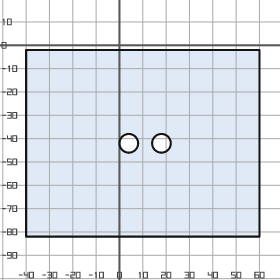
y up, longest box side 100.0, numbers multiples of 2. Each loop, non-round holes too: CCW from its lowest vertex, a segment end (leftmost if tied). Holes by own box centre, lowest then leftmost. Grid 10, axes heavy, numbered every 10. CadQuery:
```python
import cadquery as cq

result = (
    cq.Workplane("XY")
    .moveTo(-40.0, -82.0)
    .lineTo(60.0, -82.0)
    .lineTo(60.0, -2.0)
    .lineTo(-40.0, -2.0)
    .close()
    .moveTo(4.0, -42.0)
    .circle(4.0)
    .moveTo(18.0, -42.0)
    .circle(4.0)
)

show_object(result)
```